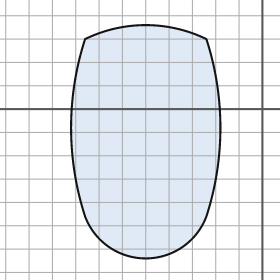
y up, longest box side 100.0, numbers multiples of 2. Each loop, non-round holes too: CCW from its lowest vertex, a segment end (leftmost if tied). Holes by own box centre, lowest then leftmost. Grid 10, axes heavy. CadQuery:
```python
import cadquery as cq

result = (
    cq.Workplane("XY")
    .moveTo(-76.0, -46.0)
    .threePointArc((-50.0, -64.0), (-24.0, -46.0))
    .threePointArc((-18.0, -8.0), (-24.0, 30.0))
    .threePointArc((-50.0, 36.0), (-76.0, 30.0))
    .threePointArc((-82.0, -8.0), (-76.0, -46.0))
    .close()
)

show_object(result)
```